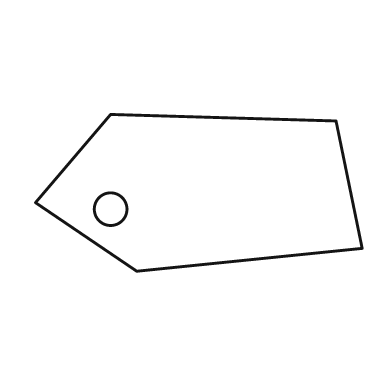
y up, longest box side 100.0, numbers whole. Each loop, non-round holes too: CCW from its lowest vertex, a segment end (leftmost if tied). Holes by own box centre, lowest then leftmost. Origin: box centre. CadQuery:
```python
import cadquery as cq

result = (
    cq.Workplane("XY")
    .moveTo(-19.0, -24.0)
    .lineTo(50.0, -17.0)
    .lineTo(42.0, 22.0)
    .lineTo(-27.0, 24.0)
    .lineTo(-50.0, -3.0)
    .close()
    .moveTo(-27.0, -5.0)
    .circle(5.0)
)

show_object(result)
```